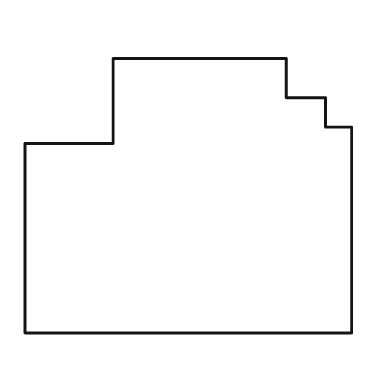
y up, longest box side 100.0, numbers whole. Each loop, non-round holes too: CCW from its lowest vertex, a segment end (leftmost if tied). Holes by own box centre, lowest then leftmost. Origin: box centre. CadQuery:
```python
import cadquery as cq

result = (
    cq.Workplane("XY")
    .moveTo(-50.0, -42.0)
    .lineTo(50.0, -42.0)
    .lineTo(50.0, 21.0)
    .lineTo(42.0, 21.0)
    .lineTo(42.0, 30.0)
    .lineTo(30.0, 30.0)
    .lineTo(30.0, 42.0)
    .lineTo(-23.0, 42.0)
    .lineTo(-23.0, 16.0)
    .lineTo(-50.0, 16.0)
    .close()
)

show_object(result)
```